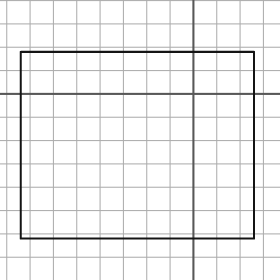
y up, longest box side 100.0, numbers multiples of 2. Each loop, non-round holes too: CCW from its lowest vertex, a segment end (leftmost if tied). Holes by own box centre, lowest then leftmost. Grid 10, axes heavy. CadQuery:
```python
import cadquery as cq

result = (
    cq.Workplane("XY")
    .moveTo(-74.0, -62.0)
    .lineTo(26.0, -62.0)
    .lineTo(26.0, 18.0)
    .lineTo(-74.0, 18.0)
    .close()
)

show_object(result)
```